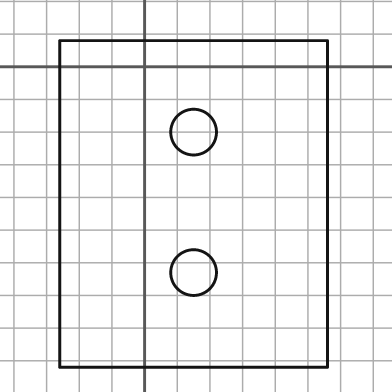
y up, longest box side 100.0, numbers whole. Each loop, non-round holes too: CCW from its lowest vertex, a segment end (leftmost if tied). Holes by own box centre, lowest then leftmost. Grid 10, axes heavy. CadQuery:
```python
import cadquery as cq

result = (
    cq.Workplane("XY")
    .moveTo(-26.0, -92.0)
    .lineTo(56.0, -92.0)
    .lineTo(56.0, 8.0)
    .lineTo(-26.0, 8.0)
    .close()
    .moveTo(15.0, -63.0)
    .circle(7.0)
    .moveTo(15.0, -20.0)
    .circle(7.0)
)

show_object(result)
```